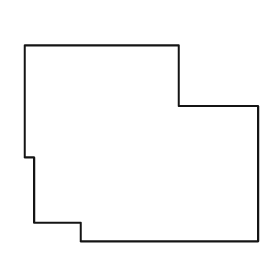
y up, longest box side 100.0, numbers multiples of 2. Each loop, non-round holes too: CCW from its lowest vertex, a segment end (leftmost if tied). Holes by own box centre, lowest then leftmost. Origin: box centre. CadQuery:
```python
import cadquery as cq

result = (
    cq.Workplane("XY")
    .moveTo(-26.0, -42.0)
    .lineTo(50.0, -42.0)
    .lineTo(50.0, 16.0)
    .lineTo(16.0, 16.0)
    .lineTo(16.0, 42.0)
    .lineTo(-50.0, 42.0)
    .lineTo(-50.0, -6.0)
    .lineTo(-46.0, -6.0)
    .lineTo(-46.0, -34.0)
    .lineTo(-26.0, -34.0)
    .close()
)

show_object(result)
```